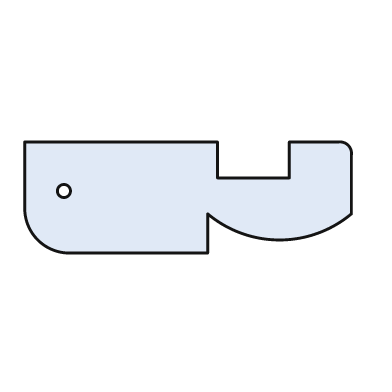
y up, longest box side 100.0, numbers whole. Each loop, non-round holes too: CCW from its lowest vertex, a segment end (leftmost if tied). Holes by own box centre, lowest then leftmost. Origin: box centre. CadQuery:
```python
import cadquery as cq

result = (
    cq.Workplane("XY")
    .moveTo(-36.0, -17.0)
    .lineTo(6.0, -17.0)
    .lineTo(6.0, -5.0)
    .threePointArc((28.0, -13.0), (50.0, -5.0))
    .lineTo(50.0, 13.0)
    .threePointArc((49.0, 16.0), (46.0, 17.0))
    .lineTo(31.0, 17.0)
    .lineTo(31.0, 6.0)
    .lineTo(9.0, 6.0)
    .lineTo(9.0, 17.0)
    .lineTo(-50.0, 17.0)
    .lineTo(-50.0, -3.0)
    .threePointArc((-46.0, -13.0), (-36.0, -17.0))
    .close()
    .moveTo(-38.0, 2.0)
    .circle(2.0)
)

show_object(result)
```